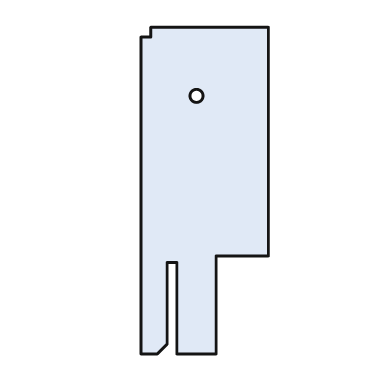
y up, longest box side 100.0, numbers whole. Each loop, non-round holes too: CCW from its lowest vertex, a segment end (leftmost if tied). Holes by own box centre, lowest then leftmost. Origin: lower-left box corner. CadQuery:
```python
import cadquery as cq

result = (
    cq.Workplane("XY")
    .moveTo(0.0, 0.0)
    .lineTo(5.0, 0.0)
    .lineTo(8.0, 3.0)
    .lineTo(8.0, 28.0)
    .lineTo(11.0, 28.0)
    .lineTo(11.0, 0.0)
    .lineTo(23.0, 0.0)
    .lineTo(23.0, 30.0)
    .lineTo(39.0, 30.0)
    .lineTo(39.0, 100.0)
    .lineTo(3.0, 100.0)
    .lineTo(3.0, 97.0)
    .lineTo(0.0, 97.0)
    .close()
    .moveTo(17.0, 79.0)
    .circle(2.0)
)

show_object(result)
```